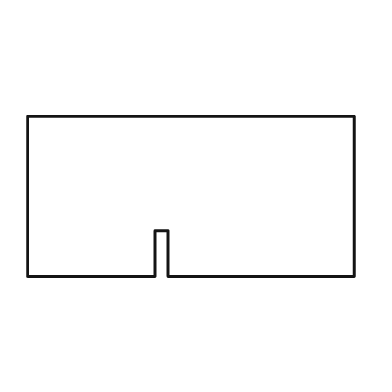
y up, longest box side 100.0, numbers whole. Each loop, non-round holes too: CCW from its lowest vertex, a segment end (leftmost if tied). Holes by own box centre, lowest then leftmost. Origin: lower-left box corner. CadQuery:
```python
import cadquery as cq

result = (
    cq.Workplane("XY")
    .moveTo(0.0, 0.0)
    .lineTo(39.0, 0.0)
    .lineTo(39.0, 14.0)
    .lineTo(43.0, 14.0)
    .lineTo(43.0, 0.0)
    .lineTo(100.0, 0.0)
    .lineTo(100.0, 49.0)
    .lineTo(0.0, 49.0)
    .close()
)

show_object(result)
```